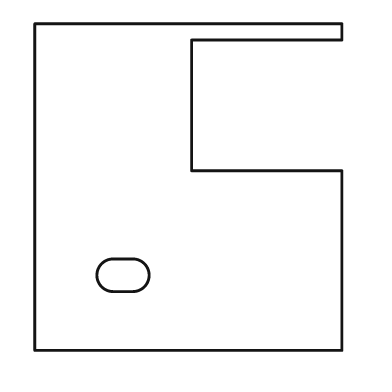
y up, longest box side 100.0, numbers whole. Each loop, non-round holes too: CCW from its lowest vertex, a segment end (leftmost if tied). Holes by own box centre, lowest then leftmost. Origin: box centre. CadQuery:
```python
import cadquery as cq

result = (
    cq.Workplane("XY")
    .moveTo(-47.0, -50.0)
    .lineTo(47.0, -50.0)
    .lineTo(47.0, 5.0)
    .lineTo(1.0, 5.0)
    .lineTo(1.0, 45.0)
    .lineTo(47.0, 45.0)
    .lineTo(47.0, 50.0)
    .lineTo(-47.0, 50.0)
    .close()
    .moveTo(-23.0, -32.0)
    .lineTo(-17.0, -32.0)
    .threePointArc((-12.0, -27.0), (-17.0, -22.0))
    .lineTo(-23.0, -22.0)
    .threePointArc((-28.0, -27.0), (-23.0, -32.0))
    .close()
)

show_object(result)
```